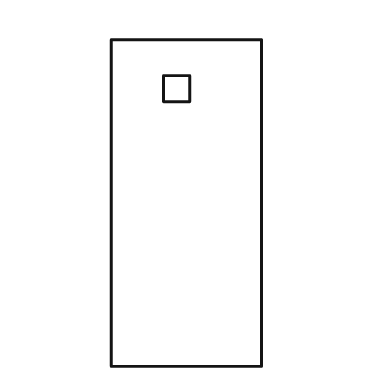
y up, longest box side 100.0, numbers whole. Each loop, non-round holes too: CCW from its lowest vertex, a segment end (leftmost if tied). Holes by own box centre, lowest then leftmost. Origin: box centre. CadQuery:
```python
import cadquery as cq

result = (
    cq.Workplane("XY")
    .moveTo(-23.0, -50.0)
    .lineTo(23.0, -50.0)
    .lineTo(23.0, 50.0)
    .lineTo(-23.0, 50.0)
    .close()
    .moveTo(-7.0, 31.0)
    .lineTo(1.0, 31.0)
    .lineTo(1.0, 39.0)
    .lineTo(-7.0, 39.0)
    .close()
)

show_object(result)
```